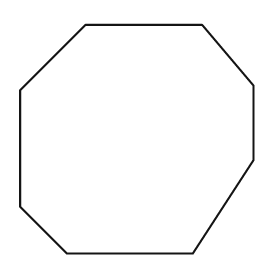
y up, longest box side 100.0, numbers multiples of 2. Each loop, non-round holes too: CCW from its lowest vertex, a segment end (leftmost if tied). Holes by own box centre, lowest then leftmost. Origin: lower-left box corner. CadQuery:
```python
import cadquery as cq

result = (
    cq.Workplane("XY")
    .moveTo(20.0, 0.0)
    .lineTo(74.0, 0.0)
    .lineTo(100.0, 40.0)
    .lineTo(100.0, 72.0)
    .lineTo(78.0, 98.0)
    .lineTo(28.0, 98.0)
    .lineTo(0.0, 70.0)
    .lineTo(0.0, 20.0)
    .close()
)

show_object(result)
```